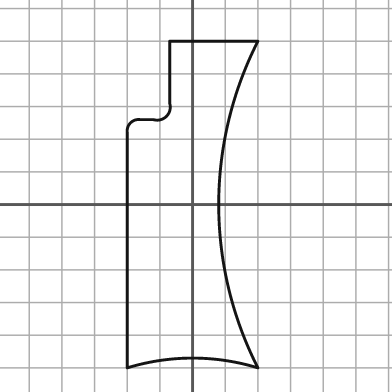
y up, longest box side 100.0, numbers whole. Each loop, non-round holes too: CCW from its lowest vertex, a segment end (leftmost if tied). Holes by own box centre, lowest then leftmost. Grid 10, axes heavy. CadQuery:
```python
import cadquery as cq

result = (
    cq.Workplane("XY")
    .moveTo(-20.0, -50.0)
    .threePointArc((0.0, -47.0), (20.0, -50.0))
    .threePointArc((8.0, 0.0), (20.0, 50.0))
    .lineTo(-7.0, 50.0)
    .lineTo(-7.0, 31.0)
    .threePointArc((-8.0, 27.0), (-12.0, 26.0))
    .lineTo(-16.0, 26.0)
    .threePointArc((-19.0, 25.0), (-20.0, 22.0))
    .close()
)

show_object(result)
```